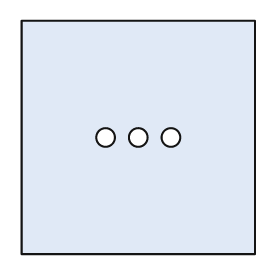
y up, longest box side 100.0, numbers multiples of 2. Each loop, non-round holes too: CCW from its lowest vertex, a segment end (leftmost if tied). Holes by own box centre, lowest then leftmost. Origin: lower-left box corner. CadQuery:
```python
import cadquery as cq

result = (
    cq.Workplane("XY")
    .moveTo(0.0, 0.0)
    .lineTo(100.0, 0.0)
    .lineTo(100.0, 100.0)
    .lineTo(0.0, 100.0)
    .close()
    .moveTo(36.0, 50.0)
    .circle(4.0)
    .moveTo(50.0, 50.0)
    .circle(4.0)
    .moveTo(64.0, 50.0)
    .circle(4.0)
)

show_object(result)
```